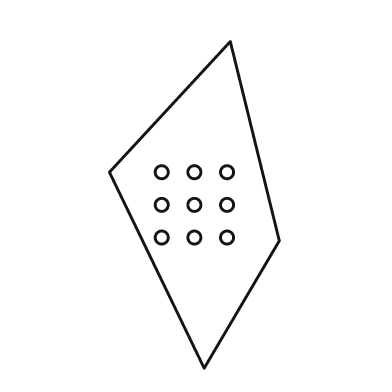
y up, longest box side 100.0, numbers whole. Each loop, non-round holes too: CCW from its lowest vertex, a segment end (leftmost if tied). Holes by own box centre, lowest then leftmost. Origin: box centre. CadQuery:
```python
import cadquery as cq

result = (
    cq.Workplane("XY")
    .moveTo(3.0, -50.0)
    .lineTo(26.0, -11.0)
    .lineTo(11.0, 50.0)
    .lineTo(-26.0, 10.0)
    .close()
    .moveTo(-10.0, -10.0)
    .circle(2.0)
    .moveTo(0.0, -10.0)
    .circle(2.0)
    .moveTo(10.0, -10.0)
    .circle(2.0)
    .moveTo(-10.0, 0.0)
    .circle(2.0)
    .moveTo(0.0, 0.0)
    .circle(2.0)
    .moveTo(10.0, 0.0)
    .circle(2.0)
    .moveTo(-10.0, 10.0)
    .circle(2.0)
    .moveTo(0.0, 10.0)
    .circle(2.0)
    .moveTo(10.0, 10.0)
    .circle(2.0)
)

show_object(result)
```